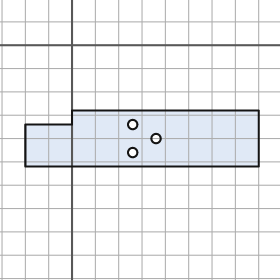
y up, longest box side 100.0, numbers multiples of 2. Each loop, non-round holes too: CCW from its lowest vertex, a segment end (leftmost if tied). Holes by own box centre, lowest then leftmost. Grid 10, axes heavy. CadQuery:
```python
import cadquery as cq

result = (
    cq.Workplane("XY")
    .moveTo(-20.0, -52.0)
    .lineTo(80.0, -52.0)
    .lineTo(80.0, -28.0)
    .lineTo(0.0, -28.0)
    .lineTo(0.0, -34.0)
    .lineTo(-20.0, -34.0)
    .close()
    .moveTo(26.0, -46.0)
    .circle(2.0)
    .moveTo(36.0, -40.0)
    .circle(2.0)
    .moveTo(26.0, -34.0)
    .circle(2.0)
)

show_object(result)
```